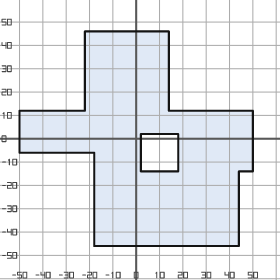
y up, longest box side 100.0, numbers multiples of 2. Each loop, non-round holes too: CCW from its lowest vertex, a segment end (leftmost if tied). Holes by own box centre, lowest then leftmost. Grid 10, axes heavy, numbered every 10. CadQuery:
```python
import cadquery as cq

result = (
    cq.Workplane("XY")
    .moveTo(-18.0, -46.0)
    .lineTo(44.0, -46.0)
    .lineTo(44.0, -14.0)
    .lineTo(50.0, -14.0)
    .lineTo(50.0, 12.0)
    .lineTo(14.0, 12.0)
    .lineTo(14.0, 46.0)
    .lineTo(-22.0, 46.0)
    .lineTo(-22.0, 12.0)
    .lineTo(-50.0, 12.0)
    .lineTo(-50.0, -6.0)
    .lineTo(-18.0, -6.0)
    .close()
    .moveTo(2.0, -14.0)
    .lineTo(18.0, -14.0)
    .lineTo(18.0, 2.0)
    .lineTo(2.0, 2.0)
    .close()
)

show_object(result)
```